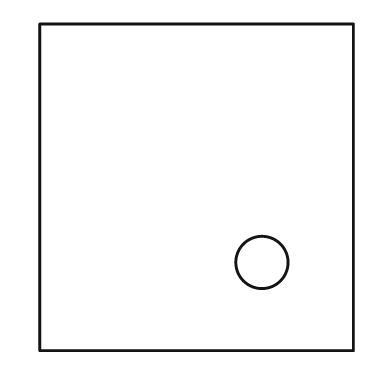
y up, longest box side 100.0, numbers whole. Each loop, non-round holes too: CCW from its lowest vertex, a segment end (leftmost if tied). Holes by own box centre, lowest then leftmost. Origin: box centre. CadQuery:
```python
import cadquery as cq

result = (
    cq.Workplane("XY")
    .moveTo(-48.0, -50.0)
    .lineTo(48.0, -50.0)
    .lineTo(48.0, 50.0)
    .lineTo(-48.0, 50.0)
    .close()
    .moveTo(20.0, -23.0)
    .circle(8.0)
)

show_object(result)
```